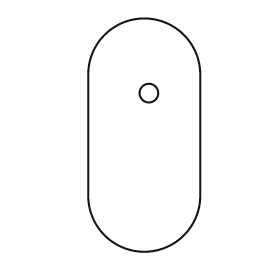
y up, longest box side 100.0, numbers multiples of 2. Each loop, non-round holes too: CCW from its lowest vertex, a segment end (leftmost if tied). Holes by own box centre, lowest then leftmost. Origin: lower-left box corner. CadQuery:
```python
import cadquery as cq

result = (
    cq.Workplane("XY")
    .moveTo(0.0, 24.0)
    .threePointArc((24.0, 0.0), (48.0, 24.0))
    .lineTo(48.0, 76.0)
    .threePointArc((24.0, 100.0), (0.0, 76.0))
    .close()
    .moveTo(26.0, 68.0)
    .circle(4.0)
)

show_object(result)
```